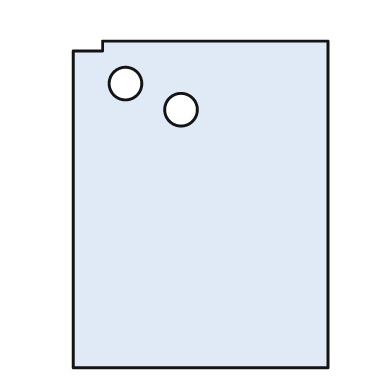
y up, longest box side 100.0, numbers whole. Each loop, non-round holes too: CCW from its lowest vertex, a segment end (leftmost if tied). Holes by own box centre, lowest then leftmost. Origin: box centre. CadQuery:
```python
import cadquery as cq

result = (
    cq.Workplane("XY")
    .moveTo(-39.0, -50.0)
    .lineTo(39.0, -50.0)
    .lineTo(39.0, 50.0)
    .lineTo(-30.0, 50.0)
    .lineTo(-30.0, 47.0)
    .lineTo(-39.0, 47.0)
    .close()
    .moveTo(-6.0, 29.0)
    .circle(5.0)
    .moveTo(-23.0, 37.0)
    .circle(5.0)
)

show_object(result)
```